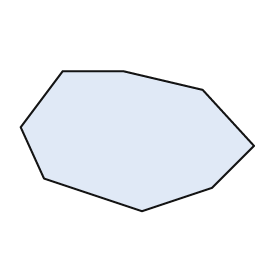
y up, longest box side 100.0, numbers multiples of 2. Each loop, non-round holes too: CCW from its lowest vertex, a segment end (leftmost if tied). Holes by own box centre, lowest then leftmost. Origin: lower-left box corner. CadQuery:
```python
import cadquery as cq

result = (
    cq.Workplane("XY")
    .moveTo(52.0, 0.0)
    .lineTo(82.0, 10.0)
    .lineTo(100.0, 28.0)
    .lineTo(78.0, 52.0)
    .lineTo(44.0, 60.0)
    .lineTo(18.0, 60.0)
    .lineTo(0.0, 36.0)
    .lineTo(10.0, 14.0)
    .close()
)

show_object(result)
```